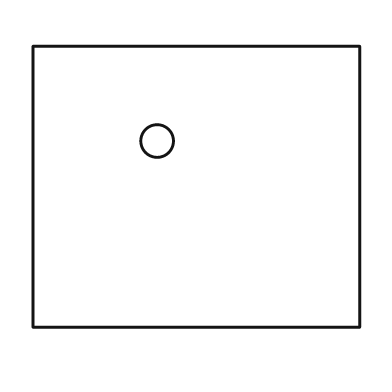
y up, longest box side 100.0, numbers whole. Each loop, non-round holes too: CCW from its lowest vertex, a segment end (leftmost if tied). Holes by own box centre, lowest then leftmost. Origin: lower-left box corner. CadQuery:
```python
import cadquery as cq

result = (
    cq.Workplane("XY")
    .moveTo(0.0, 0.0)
    .lineTo(100.0, 0.0)
    .lineTo(100.0, 86.0)
    .lineTo(0.0, 86.0)
    .close()
    .moveTo(38.0, 57.0)
    .circle(5.0)
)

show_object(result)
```